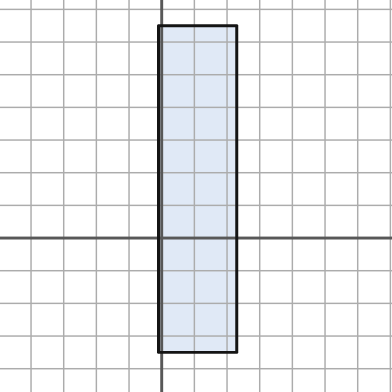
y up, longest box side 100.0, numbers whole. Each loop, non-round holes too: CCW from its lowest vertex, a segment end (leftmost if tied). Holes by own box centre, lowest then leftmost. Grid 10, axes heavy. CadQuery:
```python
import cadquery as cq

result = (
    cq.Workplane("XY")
    .moveTo(-1.0, -35.0)
    .lineTo(23.0, -35.0)
    .lineTo(23.0, 65.0)
    .lineTo(-1.0, 65.0)
    .close()
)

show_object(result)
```